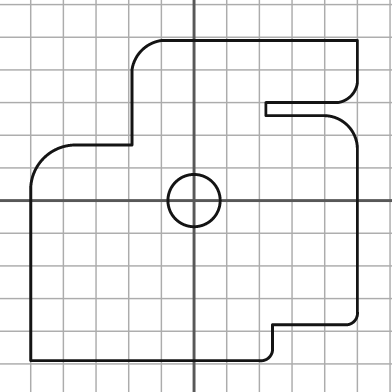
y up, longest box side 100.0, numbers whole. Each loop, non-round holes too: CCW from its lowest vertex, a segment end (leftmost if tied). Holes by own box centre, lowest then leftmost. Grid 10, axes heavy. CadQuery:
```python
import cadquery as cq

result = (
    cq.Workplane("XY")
    .moveTo(-50.0, -49.0)
    .lineTo(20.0, -49.0)
    .threePointArc((23.0, -48.0), (24.0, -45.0))
    .lineTo(24.0, -38.0)
    .lineTo(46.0, -38.0)
    .threePointArc((49.0, -37.0), (50.0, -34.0))
    .lineTo(50.0, 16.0)
    .threePointArc((47.0, 23.0), (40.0, 26.0))
    .lineTo(22.0, 26.0)
    .lineTo(22.0, 30.0)
    .lineTo(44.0, 30.0)
    .threePointArc((48.0, 32.0), (50.0, 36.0))
    .lineTo(50.0, 49.0)
    .lineTo(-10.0, 49.0)
    .threePointArc((-16.0, 46.0), (-19.0, 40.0))
    .lineTo(-19.0, 17.0)
    .lineTo(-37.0, 17.0)
    .threePointArc((-46.0, 13.0), (-50.0, 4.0))
    .close()
    .moveTo(0.0, 0.0)
    .circle(8.0)
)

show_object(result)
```